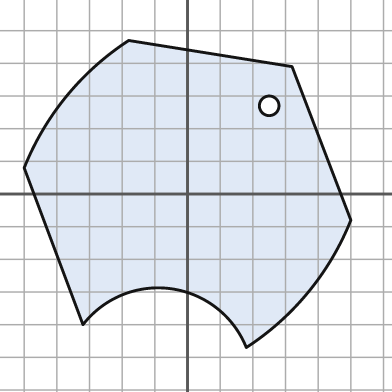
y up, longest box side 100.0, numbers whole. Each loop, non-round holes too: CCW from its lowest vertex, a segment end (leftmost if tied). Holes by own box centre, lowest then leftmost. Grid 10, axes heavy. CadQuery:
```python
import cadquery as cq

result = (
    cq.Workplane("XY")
    .moveTo(18.0, -47.0)
    .threePointArc((37.0, -30.0), (50.0, -8.0))
    .lineTo(32.0, 39.0)
    .lineTo(-18.0, 47.0)
    .threePointArc((-37.0, 30.0), (-50.0, 8.0))
    .lineTo(-32.0, -40.0)
    .threePointArc((-5.0, -29.0), (18.0, -47.0))
    .close()
    .moveTo(25.0, 27.0)
    .circle(3.0)
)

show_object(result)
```